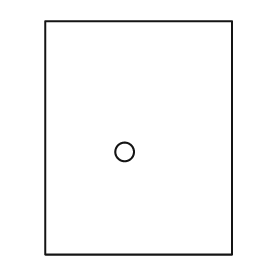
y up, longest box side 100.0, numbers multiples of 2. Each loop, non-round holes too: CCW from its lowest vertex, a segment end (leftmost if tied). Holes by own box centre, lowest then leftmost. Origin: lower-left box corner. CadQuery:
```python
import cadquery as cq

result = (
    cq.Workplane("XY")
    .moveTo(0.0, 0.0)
    .lineTo(80.0, 0.0)
    .lineTo(80.0, 100.0)
    .lineTo(0.0, 100.0)
    .close()
    .moveTo(34.0, 44.0)
    .circle(4.0)
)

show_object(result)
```